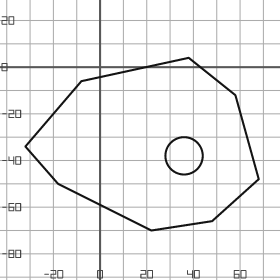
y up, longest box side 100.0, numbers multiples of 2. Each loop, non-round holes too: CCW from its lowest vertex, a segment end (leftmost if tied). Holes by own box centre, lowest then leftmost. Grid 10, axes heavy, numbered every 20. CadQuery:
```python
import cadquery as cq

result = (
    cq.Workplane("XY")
    .moveTo(22.0, -70.0)
    .lineTo(48.0, -66.0)
    .lineTo(68.0, -48.0)
    .lineTo(58.0, -12.0)
    .lineTo(38.0, 4.0)
    .lineTo(-8.0, -6.0)
    .lineTo(-32.0, -34.0)
    .lineTo(-18.0, -50.0)
    .close()
    .moveTo(36.0, -38.0)
    .circle(8.0)
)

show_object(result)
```